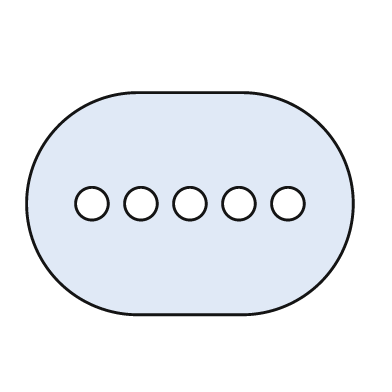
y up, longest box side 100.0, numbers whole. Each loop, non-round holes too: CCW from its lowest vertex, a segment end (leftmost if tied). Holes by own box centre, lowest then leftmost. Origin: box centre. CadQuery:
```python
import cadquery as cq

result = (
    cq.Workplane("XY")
    .moveTo(-16.0, -34.0)
    .lineTo(16.0, -34.0)
    .threePointArc((50.0, 0.0), (16.0, 34.0))
    .lineTo(-16.0, 34.0)
    .threePointArc((-50.0, 0.0), (-16.0, -34.0))
    .close()
    .moveTo(-30.0, 0.0)
    .circle(5.0)
    .moveTo(-15.0, 0.0)
    .circle(5.0)
    .moveTo(0.0, 0.0)
    .circle(5.0)
    .moveTo(15.0, 0.0)
    .circle(5.0)
    .moveTo(30.0, 0.0)
    .circle(5.0)
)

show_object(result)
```